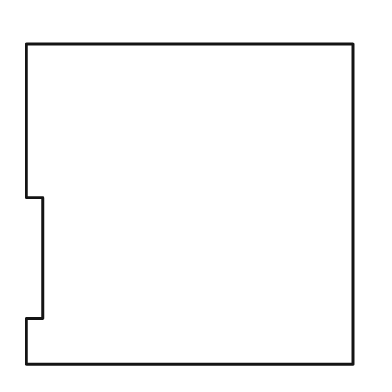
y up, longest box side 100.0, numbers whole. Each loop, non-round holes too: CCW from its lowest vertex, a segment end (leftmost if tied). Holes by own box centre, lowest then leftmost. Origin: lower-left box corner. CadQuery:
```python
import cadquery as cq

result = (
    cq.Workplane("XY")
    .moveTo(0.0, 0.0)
    .lineTo(100.0, 0.0)
    .lineTo(100.0, 98.0)
    .lineTo(0.0, 98.0)
    .lineTo(0.0, 51.0)
    .lineTo(5.0, 51.0)
    .lineTo(5.0, 14.0)
    .lineTo(0.0, 14.0)
    .close()
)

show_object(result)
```